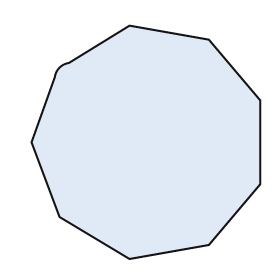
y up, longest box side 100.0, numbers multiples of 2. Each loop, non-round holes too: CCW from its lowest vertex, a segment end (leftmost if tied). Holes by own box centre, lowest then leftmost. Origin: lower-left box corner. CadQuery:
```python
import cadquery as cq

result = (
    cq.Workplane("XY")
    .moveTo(42.0, 0.0)
    .lineTo(76.0, 6.0)
    .lineTo(98.0, 32.0)
    .lineTo(98.0, 68.0)
    .lineTo(76.0, 94.0)
    .lineTo(42.0, 100.0)
    .lineTo(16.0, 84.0)
    .threePointArc((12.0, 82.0), (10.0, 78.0))
    .lineTo(0.0, 50.0)
    .lineTo(12.0, 18.0)
    .close()
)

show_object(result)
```